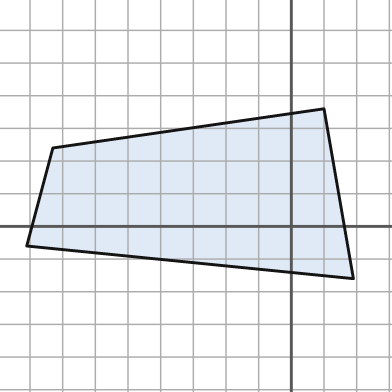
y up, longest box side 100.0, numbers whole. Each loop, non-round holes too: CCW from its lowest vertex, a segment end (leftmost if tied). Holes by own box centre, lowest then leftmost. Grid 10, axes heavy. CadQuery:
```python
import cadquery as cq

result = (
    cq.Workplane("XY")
    .moveTo(19.0, -16.0)
    .lineTo(10.0, 36.0)
    .lineTo(-73.0, 24.0)
    .lineTo(-81.0, -6.0)
    .close()
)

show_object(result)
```